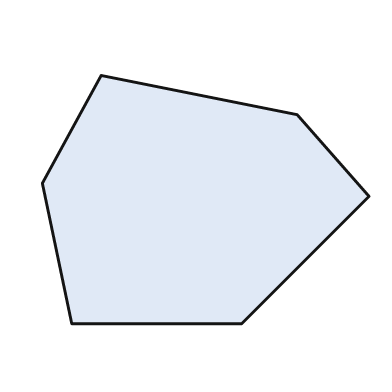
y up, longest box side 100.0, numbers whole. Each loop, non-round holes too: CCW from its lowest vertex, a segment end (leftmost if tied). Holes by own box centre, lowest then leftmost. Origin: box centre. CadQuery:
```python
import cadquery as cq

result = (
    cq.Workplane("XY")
    .moveTo(-41.0, -38.0)
    .lineTo(11.0, -38.0)
    .lineTo(50.0, 1.0)
    .lineTo(28.0, 26.0)
    .lineTo(-32.0, 38.0)
    .lineTo(-50.0, 5.0)
    .close()
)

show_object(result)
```